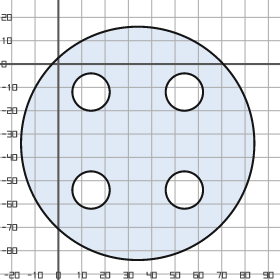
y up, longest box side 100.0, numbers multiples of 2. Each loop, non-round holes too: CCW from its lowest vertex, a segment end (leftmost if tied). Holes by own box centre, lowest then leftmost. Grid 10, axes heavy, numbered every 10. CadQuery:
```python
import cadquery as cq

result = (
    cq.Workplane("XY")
    .moveTo(34.0, -34.0)
    .circle(50.0)
    .moveTo(14.0, -54.0)
    .circle(8.0)
    .moveTo(54.0, -54.0)
    .circle(8.0)
    .moveTo(14.0, -12.0)
    .circle(8.0)
    .moveTo(54.0, -12.0)
    .circle(8.0)
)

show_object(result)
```